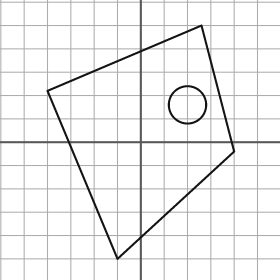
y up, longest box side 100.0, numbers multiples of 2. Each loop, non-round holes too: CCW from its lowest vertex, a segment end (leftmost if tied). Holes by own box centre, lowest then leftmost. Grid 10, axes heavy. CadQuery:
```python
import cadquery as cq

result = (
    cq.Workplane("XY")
    .moveTo(-10.0, -50.0)
    .lineTo(40.0, -4.0)
    .lineTo(26.0, 50.0)
    .lineTo(-40.0, 22.0)
    .close()
    .moveTo(20.0, 16.0)
    .circle(8.0)
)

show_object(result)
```